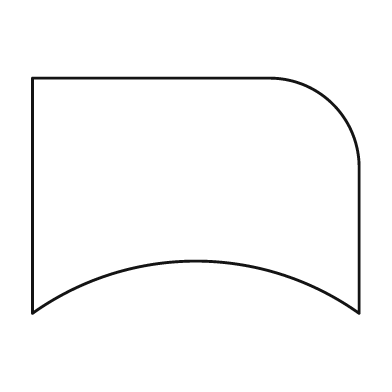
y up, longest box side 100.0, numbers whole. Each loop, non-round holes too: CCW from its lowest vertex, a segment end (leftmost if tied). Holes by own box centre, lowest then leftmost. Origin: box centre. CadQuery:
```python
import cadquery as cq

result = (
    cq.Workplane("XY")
    .moveTo(-50.0, -36.0)
    .threePointArc((0.0, -20.0), (50.0, -36.0))
    .lineTo(50.0, 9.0)
    .threePointArc((42.0, 28.0), (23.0, 36.0))
    .lineTo(-50.0, 36.0)
    .close()
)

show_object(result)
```